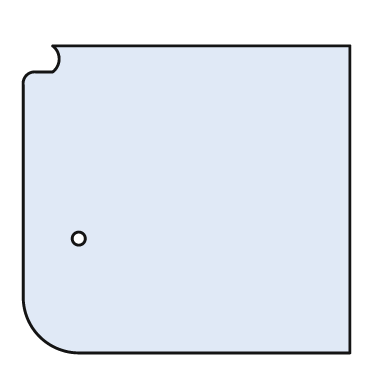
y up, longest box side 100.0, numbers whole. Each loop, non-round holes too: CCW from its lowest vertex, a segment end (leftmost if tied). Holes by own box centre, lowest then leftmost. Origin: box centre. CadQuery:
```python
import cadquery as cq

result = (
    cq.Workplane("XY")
    .moveTo(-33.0, -47.0)
    .lineTo(50.0, -47.0)
    .lineTo(50.0, 47.0)
    .lineTo(-41.0, 47.0)
    .threePointArc((-39.0, 43.0), (-41.0, 39.0))
    .lineTo(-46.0, 39.0)
    .threePointArc((-49.0, 38.0), (-50.0, 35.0))
    .lineTo(-50.0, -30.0)
    .threePointArc((-45.0, -42.0), (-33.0, -47.0))
    .close()
    .moveTo(-33.0, -12.0)
    .circle(2.0)
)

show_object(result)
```